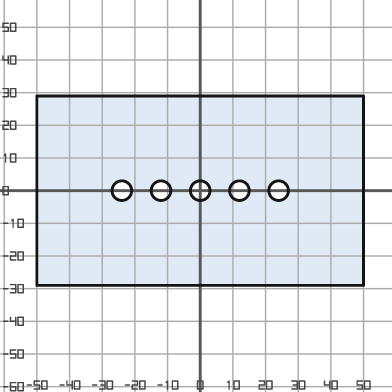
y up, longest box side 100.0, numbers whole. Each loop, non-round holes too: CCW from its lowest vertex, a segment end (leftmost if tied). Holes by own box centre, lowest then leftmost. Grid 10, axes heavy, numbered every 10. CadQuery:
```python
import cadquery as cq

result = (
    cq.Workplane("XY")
    .moveTo(-50.0, -29.0)
    .lineTo(50.0, -29.0)
    .lineTo(50.0, 29.0)
    .lineTo(-50.0, 29.0)
    .close()
    .moveTo(-24.0, 0.0)
    .circle(3.0)
    .moveTo(-12.0, 0.0)
    .circle(3.0)
    .moveTo(0.0, 0.0)
    .circle(3.0)
    .moveTo(12.0, 0.0)
    .circle(3.0)
    .moveTo(24.0, 0.0)
    .circle(3.0)
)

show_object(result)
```